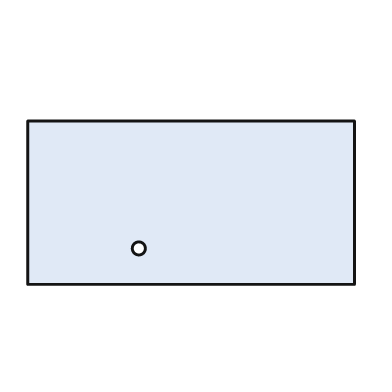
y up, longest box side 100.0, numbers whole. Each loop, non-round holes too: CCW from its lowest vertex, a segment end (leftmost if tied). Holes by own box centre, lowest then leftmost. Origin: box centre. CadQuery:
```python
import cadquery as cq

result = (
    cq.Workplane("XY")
    .moveTo(-50.0, -25.0)
    .lineTo(50.0, -25.0)
    .lineTo(50.0, 25.0)
    .lineTo(-50.0, 25.0)
    .close()
    .moveTo(-16.0, -14.0)
    .circle(2.0)
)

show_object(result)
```